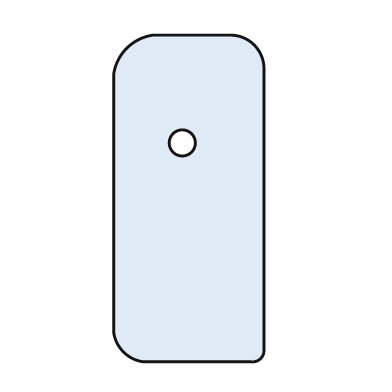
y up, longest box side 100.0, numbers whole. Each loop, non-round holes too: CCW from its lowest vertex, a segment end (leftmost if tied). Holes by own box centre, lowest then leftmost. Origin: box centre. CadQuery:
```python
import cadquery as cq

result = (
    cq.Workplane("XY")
    .moveTo(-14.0, -50.0)
    .lineTo(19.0, -50.0)
    .threePointArc((22.0, -49.0), (23.0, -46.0))
    .lineTo(23.0, 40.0)
    .threePointArc((20.0, 47.0), (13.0, 50.0))
    .lineTo(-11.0, 50.0)
    .threePointArc((-19.0, 46.0), (-23.0, 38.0))
    .lineTo(-23.0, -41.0)
    .threePointArc((-20.0, -47.0), (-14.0, -50.0))
    .close()
    .moveTo(-2.0, 17.0)
    .circle(4.0)
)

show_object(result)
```